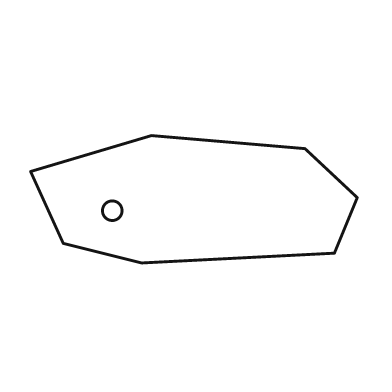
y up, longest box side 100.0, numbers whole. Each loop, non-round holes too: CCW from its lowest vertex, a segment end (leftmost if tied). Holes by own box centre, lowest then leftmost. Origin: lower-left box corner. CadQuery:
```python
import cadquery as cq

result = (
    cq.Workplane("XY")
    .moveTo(34.0, 0.0)
    .lineTo(93.0, 3.0)
    .lineTo(100.0, 20.0)
    .lineTo(84.0, 35.0)
    .lineTo(37.0, 39.0)
    .lineTo(0.0, 28.0)
    .lineTo(10.0, 6.0)
    .close()
    .moveTo(25.0, 16.0)
    .circle(3.0)
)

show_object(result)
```